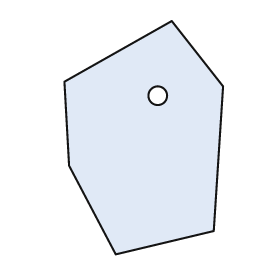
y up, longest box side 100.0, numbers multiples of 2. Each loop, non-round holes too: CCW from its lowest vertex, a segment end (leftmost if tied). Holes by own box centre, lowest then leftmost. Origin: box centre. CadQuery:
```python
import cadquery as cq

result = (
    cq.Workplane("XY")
    .moveTo(-12.0, -50.0)
    .lineTo(30.0, -40.0)
    .lineTo(34.0, 22.0)
    .lineTo(12.0, 50.0)
    .lineTo(-34.0, 24.0)
    .lineTo(-32.0, -12.0)
    .close()
    .moveTo(6.0, 18.0)
    .circle(4.0)
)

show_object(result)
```